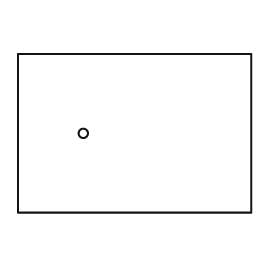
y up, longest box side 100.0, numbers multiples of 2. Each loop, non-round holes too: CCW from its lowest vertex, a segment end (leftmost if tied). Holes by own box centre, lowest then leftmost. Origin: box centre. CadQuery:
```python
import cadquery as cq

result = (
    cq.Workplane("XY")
    .moveTo(-50.0, -34.0)
    .lineTo(50.0, -34.0)
    .lineTo(50.0, 34.0)
    .lineTo(-50.0, 34.0)
    .close()
    .moveTo(-22.0, 0.0)
    .circle(2.0)
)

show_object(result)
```